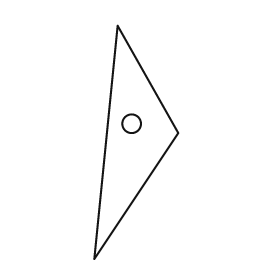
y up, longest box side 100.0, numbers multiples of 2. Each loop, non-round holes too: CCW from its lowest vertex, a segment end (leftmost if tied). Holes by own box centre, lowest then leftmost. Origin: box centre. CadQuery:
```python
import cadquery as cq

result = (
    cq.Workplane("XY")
    .moveTo(-18.0, -50.0)
    .lineTo(18.0, 4.0)
    .lineTo(-8.0, 50.0)
    .close()
    .moveTo(-2.0, 8.0)
    .circle(4.0)
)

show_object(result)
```